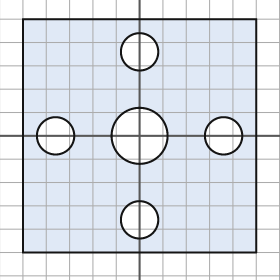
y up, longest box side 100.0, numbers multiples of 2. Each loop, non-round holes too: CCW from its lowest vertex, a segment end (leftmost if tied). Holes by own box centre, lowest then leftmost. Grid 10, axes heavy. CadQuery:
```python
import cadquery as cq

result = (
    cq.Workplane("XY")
    .moveTo(-50.0, -50.0)
    .lineTo(50.0, -50.0)
    .lineTo(50.0, 50.0)
    .lineTo(-50.0, 50.0)
    .close()
    .moveTo(0.0, -36.0)
    .circle(8.0)
    .moveTo(-36.0, 0.0)
    .circle(8.0)
    .moveTo(0.0, 0.0)
    .circle(12.0)
    .moveTo(36.0, 0.0)
    .circle(8.0)
    .moveTo(0.0, 36.0)
    .circle(8.0)
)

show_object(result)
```